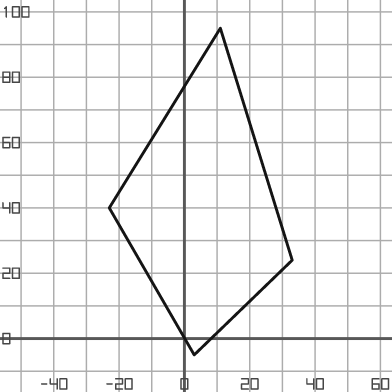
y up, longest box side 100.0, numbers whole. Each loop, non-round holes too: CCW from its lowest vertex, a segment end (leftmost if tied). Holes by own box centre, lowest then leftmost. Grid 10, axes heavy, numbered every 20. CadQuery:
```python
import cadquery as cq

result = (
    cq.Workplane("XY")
    .moveTo(3.0, -5.0)
    .lineTo(33.0, 24.0)
    .lineTo(11.0, 95.0)
    .lineTo(-23.0, 40.0)
    .close()
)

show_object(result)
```